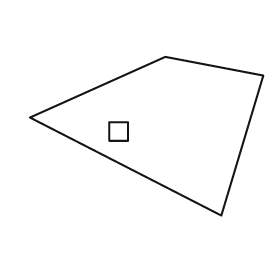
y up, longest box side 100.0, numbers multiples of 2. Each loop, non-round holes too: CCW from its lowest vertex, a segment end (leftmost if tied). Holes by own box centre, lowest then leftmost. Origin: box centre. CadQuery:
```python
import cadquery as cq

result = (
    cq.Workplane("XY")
    .moveTo(32.0, -34.0)
    .lineTo(50.0, 26.0)
    .lineTo(8.0, 34.0)
    .lineTo(-50.0, 8.0)
    .close()
    .moveTo(-16.0, -2.0)
    .lineTo(-8.0, -2.0)
    .lineTo(-8.0, 6.0)
    .lineTo(-16.0, 6.0)
    .close()
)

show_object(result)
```